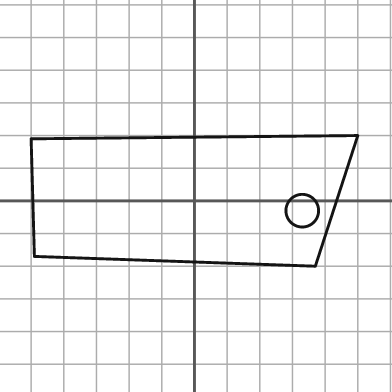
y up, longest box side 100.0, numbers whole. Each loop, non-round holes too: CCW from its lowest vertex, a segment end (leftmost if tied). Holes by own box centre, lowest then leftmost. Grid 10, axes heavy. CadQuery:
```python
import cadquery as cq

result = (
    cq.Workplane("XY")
    .moveTo(37.0, -20.0)
    .lineTo(50.0, 20.0)
    .lineTo(-50.0, 19.0)
    .lineTo(-49.0, -17.0)
    .close()
    .moveTo(33.0, -3.0)
    .circle(5.0)
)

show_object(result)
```